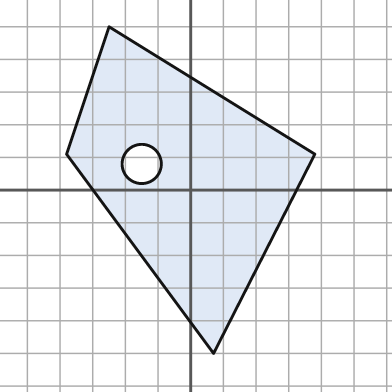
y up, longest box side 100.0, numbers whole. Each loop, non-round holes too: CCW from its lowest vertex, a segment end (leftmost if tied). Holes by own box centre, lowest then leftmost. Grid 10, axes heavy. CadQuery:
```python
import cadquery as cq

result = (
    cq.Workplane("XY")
    .moveTo(7.0, -50.0)
    .lineTo(38.0, 11.0)
    .lineTo(-25.0, 50.0)
    .lineTo(-38.0, 11.0)
    .close()
    .moveTo(-15.0, 8.0)
    .circle(6.0)
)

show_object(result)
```